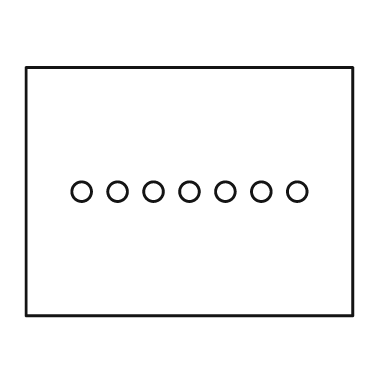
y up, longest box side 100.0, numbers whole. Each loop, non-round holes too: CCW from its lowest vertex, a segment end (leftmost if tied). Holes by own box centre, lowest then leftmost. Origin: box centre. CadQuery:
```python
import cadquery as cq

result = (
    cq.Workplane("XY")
    .moveTo(-50.0, -38.0)
    .lineTo(50.0, -38.0)
    .lineTo(50.0, 38.0)
    .lineTo(-50.0, 38.0)
    .close()
    .moveTo(-33.0, 0.0)
    .circle(3.0)
    .moveTo(-22.0, 0.0)
    .circle(3.0)
    .moveTo(-11.0, 0.0)
    .circle(3.0)
    .moveTo(0.0, 0.0)
    .circle(3.0)
    .moveTo(11.0, 0.0)
    .circle(3.0)
    .moveTo(22.0, 0.0)
    .circle(3.0)
    .moveTo(33.0, 0.0)
    .circle(3.0)
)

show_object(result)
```